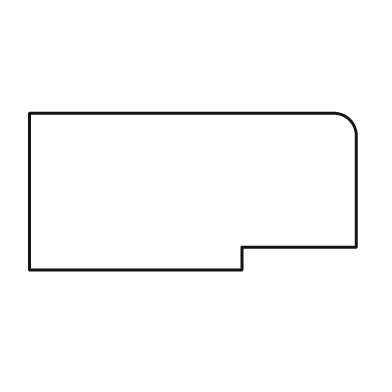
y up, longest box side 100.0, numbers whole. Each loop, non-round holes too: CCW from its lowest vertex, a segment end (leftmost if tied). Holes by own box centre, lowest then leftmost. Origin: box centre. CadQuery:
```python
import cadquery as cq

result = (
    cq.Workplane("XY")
    .moveTo(-50.0, -24.0)
    .lineTo(15.0, -24.0)
    .lineTo(15.0, -17.0)
    .lineTo(50.0, -17.0)
    .lineTo(50.0, 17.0)
    .threePointArc((48.0, 22.0), (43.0, 24.0))
    .lineTo(-50.0, 24.0)
    .close()
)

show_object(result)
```